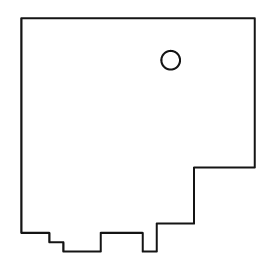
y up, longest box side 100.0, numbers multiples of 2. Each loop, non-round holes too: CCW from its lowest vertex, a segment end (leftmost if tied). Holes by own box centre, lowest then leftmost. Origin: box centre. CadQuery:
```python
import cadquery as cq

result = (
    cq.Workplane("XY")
    .moveTo(-32.0, -50.0)
    .lineTo(-16.0, -50.0)
    .lineTo(-16.0, -42.0)
    .lineTo(2.0, -42.0)
    .lineTo(2.0, -50.0)
    .lineTo(8.0, -50.0)
    .lineTo(8.0, -38.0)
    .lineTo(24.0, -38.0)
    .lineTo(24.0, -14.0)
    .lineTo(50.0, -14.0)
    .lineTo(50.0, 50.0)
    .lineTo(-50.0, 50.0)
    .lineTo(-50.0, -42.0)
    .lineTo(-38.0, -42.0)
    .lineTo(-38.0, -46.0)
    .lineTo(-32.0, -46.0)
    .close()
    .moveTo(14.0, 32.0)
    .circle(4.0)
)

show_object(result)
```